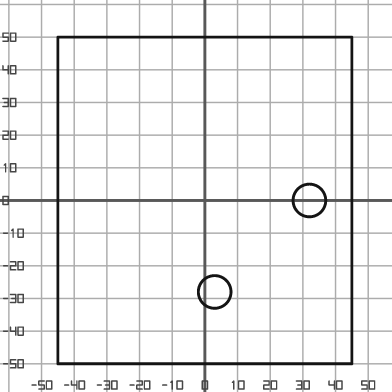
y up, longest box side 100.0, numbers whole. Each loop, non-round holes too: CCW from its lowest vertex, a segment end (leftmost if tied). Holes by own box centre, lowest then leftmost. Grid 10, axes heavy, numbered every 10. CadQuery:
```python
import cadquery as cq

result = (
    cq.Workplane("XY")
    .moveTo(-45.0, -50.0)
    .lineTo(45.0, -50.0)
    .lineTo(45.0, 50.0)
    .lineTo(-45.0, 50.0)
    .close()
    .moveTo(3.0, -28.0)
    .circle(5.0)
    .moveTo(32.0, 0.0)
    .circle(5.0)
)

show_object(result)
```